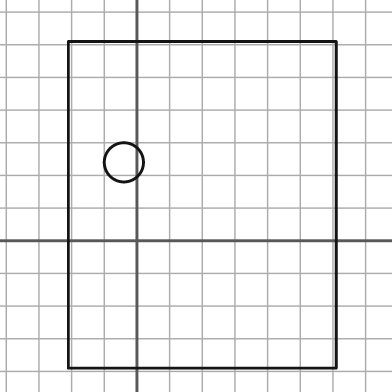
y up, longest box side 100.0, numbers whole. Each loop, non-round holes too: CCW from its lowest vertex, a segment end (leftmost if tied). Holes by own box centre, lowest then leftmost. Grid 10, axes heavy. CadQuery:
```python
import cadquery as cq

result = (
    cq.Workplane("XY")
    .moveTo(-21.0, -39.0)
    .lineTo(61.0, -39.0)
    .lineTo(61.0, 61.0)
    .lineTo(-21.0, 61.0)
    .close()
    .moveTo(-4.0, 24.0)
    .circle(6.0)
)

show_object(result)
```